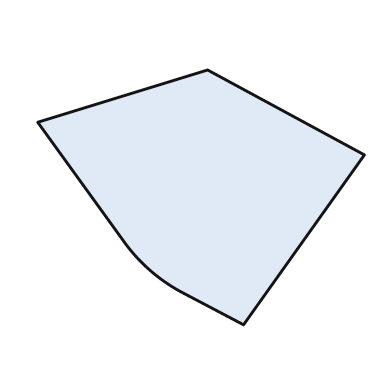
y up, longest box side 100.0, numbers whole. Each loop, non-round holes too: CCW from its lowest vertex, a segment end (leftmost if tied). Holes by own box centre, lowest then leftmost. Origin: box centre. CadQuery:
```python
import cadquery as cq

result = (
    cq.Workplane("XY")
    .moveTo(13.0, -39.0)
    .lineTo(50.0, 13.0)
    .lineTo(2.0, 39.0)
    .lineTo(-50.0, 23.0)
    .lineTo(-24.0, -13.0)
    .threePointArc((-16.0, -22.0), (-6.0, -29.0))
    .close()
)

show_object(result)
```